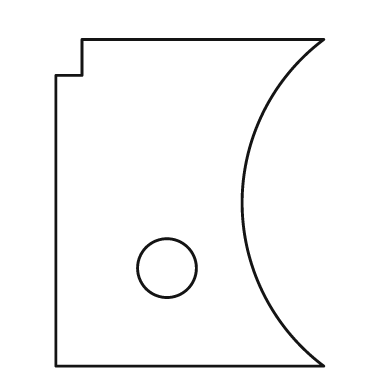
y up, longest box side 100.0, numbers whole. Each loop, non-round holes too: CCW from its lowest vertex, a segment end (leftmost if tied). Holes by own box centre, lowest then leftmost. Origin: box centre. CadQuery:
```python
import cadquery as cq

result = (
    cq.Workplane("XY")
    .moveTo(-41.0, -50.0)
    .lineTo(41.0, -50.0)
    .threePointArc((16.0, 0.0), (41.0, 50.0))
    .lineTo(-33.0, 50.0)
    .lineTo(-33.0, 39.0)
    .lineTo(-41.0, 39.0)
    .close()
    .moveTo(-7.0, -20.0)
    .circle(9.0)
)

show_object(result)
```